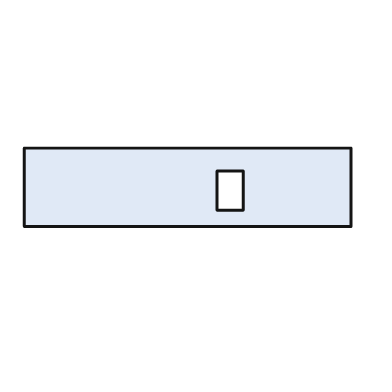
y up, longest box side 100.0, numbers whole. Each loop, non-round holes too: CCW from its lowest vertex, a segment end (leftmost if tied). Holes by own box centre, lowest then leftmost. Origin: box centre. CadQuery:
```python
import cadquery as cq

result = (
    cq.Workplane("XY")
    .moveTo(-50.0, -12.0)
    .lineTo(50.0, -12.0)
    .lineTo(50.0, 12.0)
    .lineTo(-50.0, 12.0)
    .close()
    .moveTo(9.0, -7.0)
    .lineTo(17.0, -7.0)
    .lineTo(17.0, 5.0)
    .lineTo(9.0, 5.0)
    .close()
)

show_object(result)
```